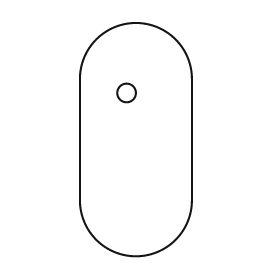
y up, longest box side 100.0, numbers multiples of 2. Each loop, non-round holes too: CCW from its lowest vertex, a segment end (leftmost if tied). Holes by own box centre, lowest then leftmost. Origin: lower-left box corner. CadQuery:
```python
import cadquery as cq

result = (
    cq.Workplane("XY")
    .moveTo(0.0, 24.0)
    .threePointArc((24.0, 0.0), (48.0, 24.0))
    .lineTo(48.0, 76.0)
    .threePointArc((24.0, 100.0), (0.0, 76.0))
    .close()
    .moveTo(20.0, 70.0)
    .circle(4.0)
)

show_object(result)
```